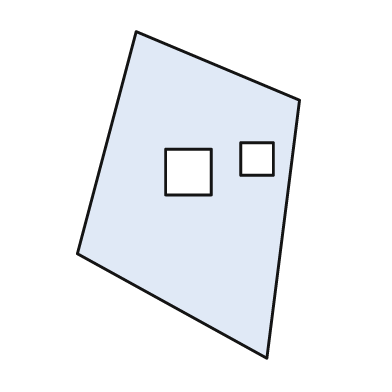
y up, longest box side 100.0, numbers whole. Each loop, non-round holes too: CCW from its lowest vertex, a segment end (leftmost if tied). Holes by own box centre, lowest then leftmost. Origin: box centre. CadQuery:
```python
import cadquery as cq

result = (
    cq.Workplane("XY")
    .moveTo(24.0, -50.0)
    .lineTo(34.0, 29.0)
    .lineTo(-16.0, 50.0)
    .lineTo(-34.0, -18.0)
    .close()
    .moveTo(-7.0, 0.0)
    .lineTo(7.0, 0.0)
    .lineTo(7.0, 14.0)
    .lineTo(-7.0, 14.0)
    .close()
    .moveTo(16.0, 6.0)
    .lineTo(26.0, 6.0)
    .lineTo(26.0, 16.0)
    .lineTo(16.0, 16.0)
    .close()
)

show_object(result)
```